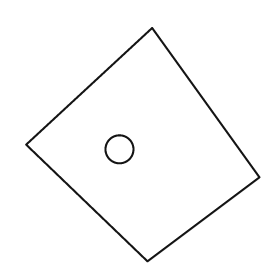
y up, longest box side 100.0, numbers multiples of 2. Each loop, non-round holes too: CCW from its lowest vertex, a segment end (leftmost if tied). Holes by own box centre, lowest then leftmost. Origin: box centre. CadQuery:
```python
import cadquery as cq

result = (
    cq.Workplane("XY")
    .moveTo(2.0, -50.0)
    .lineTo(50.0, -14.0)
    .lineTo(4.0, 50.0)
    .lineTo(-50.0, 0.0)
    .close()
    .moveTo(-10.0, -2.0)
    .circle(6.0)
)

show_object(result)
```